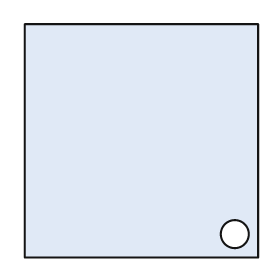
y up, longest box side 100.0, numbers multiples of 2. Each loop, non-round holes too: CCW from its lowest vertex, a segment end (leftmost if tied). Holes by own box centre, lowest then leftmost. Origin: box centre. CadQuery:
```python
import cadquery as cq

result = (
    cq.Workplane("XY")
    .moveTo(-50.0, -50.0)
    .lineTo(50.0, -50.0)
    .lineTo(50.0, 50.0)
    .lineTo(-50.0, 50.0)
    .close()
    .moveTo(40.0, -40.0)
    .circle(6.0)
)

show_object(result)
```